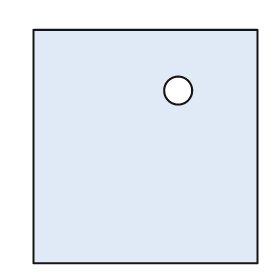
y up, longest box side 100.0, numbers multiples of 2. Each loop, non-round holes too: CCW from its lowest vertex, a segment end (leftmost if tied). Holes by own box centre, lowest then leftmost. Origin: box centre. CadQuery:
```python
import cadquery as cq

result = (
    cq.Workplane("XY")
    .moveTo(-48.0, -50.0)
    .lineTo(48.0, -50.0)
    .lineTo(48.0, 50.0)
    .lineTo(-48.0, 50.0)
    .close()
    .moveTo(14.0, 24.0)
    .circle(6.0)
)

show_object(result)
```